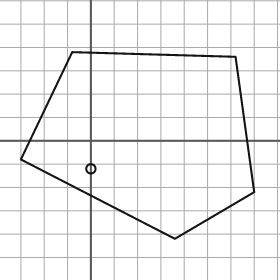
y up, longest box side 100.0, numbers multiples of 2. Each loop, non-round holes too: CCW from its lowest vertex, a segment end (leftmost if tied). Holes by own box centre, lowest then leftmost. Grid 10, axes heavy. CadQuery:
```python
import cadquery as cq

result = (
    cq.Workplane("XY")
    .moveTo(36.0, -42.0)
    .lineTo(70.0, -22.0)
    .lineTo(62.0, 36.0)
    .lineTo(-8.0, 38.0)
    .lineTo(-30.0, -8.0)
    .close()
    .moveTo(0.0, -12.0)
    .circle(2.0)
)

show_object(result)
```